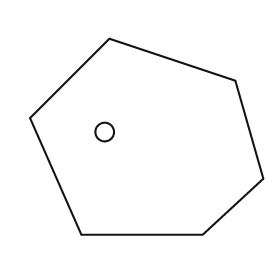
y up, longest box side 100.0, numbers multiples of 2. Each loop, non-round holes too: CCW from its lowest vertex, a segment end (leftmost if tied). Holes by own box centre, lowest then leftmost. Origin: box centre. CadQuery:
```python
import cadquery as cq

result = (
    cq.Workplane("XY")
    .moveTo(-28.0, -42.0)
    .lineTo(24.0, -42.0)
    .lineTo(50.0, -18.0)
    .lineTo(38.0, 24.0)
    .lineTo(-16.0, 42.0)
    .lineTo(-50.0, 8.0)
    .close()
    .moveTo(-18.0, 2.0)
    .circle(4.0)
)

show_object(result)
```